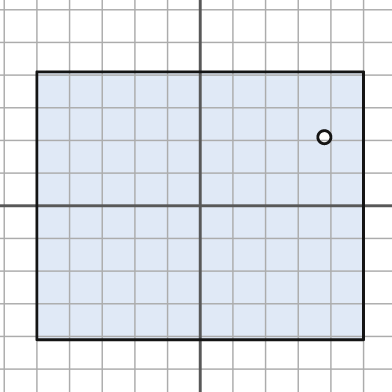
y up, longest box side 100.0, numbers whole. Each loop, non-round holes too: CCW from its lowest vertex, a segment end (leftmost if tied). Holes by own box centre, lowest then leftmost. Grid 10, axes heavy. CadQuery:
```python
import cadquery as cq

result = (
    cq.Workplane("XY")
    .moveTo(-50.0, -41.0)
    .lineTo(50.0, -41.0)
    .lineTo(50.0, 41.0)
    .lineTo(-50.0, 41.0)
    .close()
    .moveTo(38.0, 21.0)
    .circle(2.0)
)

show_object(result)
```